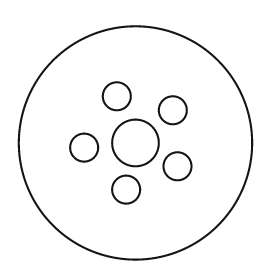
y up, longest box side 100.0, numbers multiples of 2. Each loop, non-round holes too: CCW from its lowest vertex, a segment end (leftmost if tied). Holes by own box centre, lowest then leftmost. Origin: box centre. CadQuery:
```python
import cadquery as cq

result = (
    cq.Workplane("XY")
    .moveTo(0.0, 0.0)
    .circle(50.0)
    .moveTo(-4.0, -20.0)
    .circle(6.0)
    .moveTo(18.0, -10.0)
    .circle(6.0)
    .moveTo(-22.0, -2.0)
    .circle(6.0)
    .moveTo(0.0, 0.0)
    .circle(10.0)
    .moveTo(16.0, 14.0)
    .circle(6.0)
    .moveTo(-8.0, 20.0)
    .circle(6.0)
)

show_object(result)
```